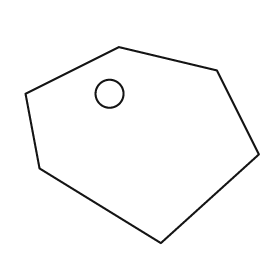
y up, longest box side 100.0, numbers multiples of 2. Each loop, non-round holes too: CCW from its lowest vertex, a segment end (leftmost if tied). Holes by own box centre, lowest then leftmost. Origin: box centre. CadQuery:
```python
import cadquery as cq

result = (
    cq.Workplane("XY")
    .moveTo(8.0, -42.0)
    .lineTo(50.0, -4.0)
    .lineTo(32.0, 32.0)
    .lineTo(-10.0, 42.0)
    .lineTo(-50.0, 22.0)
    .lineTo(-44.0, -10.0)
    .close()
    .moveTo(-14.0, 22.0)
    .circle(6.0)
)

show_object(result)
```